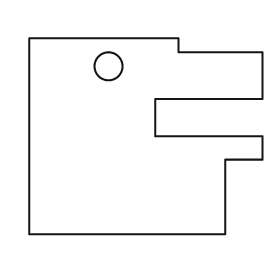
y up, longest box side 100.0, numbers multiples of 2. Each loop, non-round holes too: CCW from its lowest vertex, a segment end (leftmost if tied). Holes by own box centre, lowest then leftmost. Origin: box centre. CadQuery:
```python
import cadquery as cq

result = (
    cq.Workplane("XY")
    .moveTo(-50.0, -42.0)
    .lineTo(34.0, -42.0)
    .lineTo(34.0, -10.0)
    .lineTo(50.0, -10.0)
    .lineTo(50.0, 0.0)
    .lineTo(4.0, 0.0)
    .lineTo(4.0, 16.0)
    .lineTo(50.0, 16.0)
    .lineTo(50.0, 36.0)
    .lineTo(14.0, 36.0)
    .lineTo(14.0, 42.0)
    .lineTo(-50.0, 42.0)
    .close()
    .moveTo(-16.0, 30.0)
    .circle(6.0)
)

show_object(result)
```